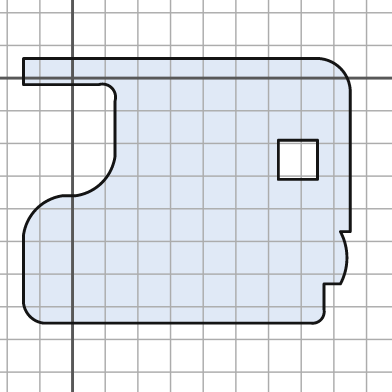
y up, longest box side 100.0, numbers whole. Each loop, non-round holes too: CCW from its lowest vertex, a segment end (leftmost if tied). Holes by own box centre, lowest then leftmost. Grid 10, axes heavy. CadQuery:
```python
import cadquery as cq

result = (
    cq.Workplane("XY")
    .moveTo(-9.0, -75.0)
    .lineTo(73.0, -75.0)
    .threePointArc((76.0, -74.0), (77.0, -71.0))
    .lineTo(77.0, -63.0)
    .lineTo(82.0, -63.0)
    .threePointArc((84.0, -55.0), (82.0, -47.0))
    .lineTo(85.0, -47.0)
    .lineTo(85.0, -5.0)
    .threePointArc((82.0, 3.0), (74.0, 6.0))
    .lineTo(-15.0, 6.0)
    .lineTo(-15.0, -2.0)
    .lineTo(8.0, -2.0)
    .threePointArc((12.0, -3.0), (13.0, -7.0))
    .lineTo(13.0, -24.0)
    .threePointArc((9.0, -32.0), (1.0, -36.0))
    .lineTo(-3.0, -36.0)
    .threePointArc((-11.0, -40.0), (-15.0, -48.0))
    .lineTo(-15.0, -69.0)
    .threePointArc((-13.0, -73.0), (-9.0, -75.0))
    .close()
    .moveTo(63.0, -31.0)
    .lineTo(75.0, -31.0)
    .lineTo(75.0, -19.0)
    .lineTo(63.0, -19.0)
    .close()
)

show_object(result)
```